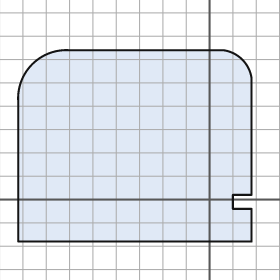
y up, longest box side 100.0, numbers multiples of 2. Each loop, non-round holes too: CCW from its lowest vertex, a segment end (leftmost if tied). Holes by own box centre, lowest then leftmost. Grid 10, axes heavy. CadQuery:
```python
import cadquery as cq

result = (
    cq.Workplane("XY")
    .moveTo(-82.0, -18.0)
    .lineTo(18.0, -18.0)
    .lineTo(18.0, -4.0)
    .lineTo(10.0, -4.0)
    .lineTo(10.0, 2.0)
    .lineTo(18.0, 2.0)
    .lineTo(18.0, 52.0)
    .threePointArc((14.0, 60.0), (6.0, 64.0))
    .lineTo(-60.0, 64.0)
    .threePointArc((-76.0, 58.0), (-82.0, 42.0))
    .close()
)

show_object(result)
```